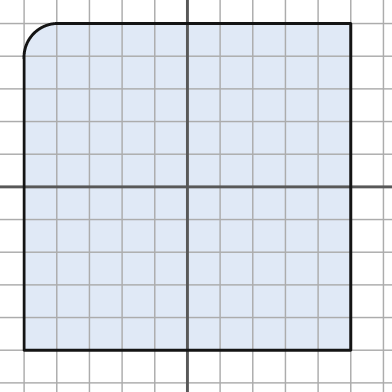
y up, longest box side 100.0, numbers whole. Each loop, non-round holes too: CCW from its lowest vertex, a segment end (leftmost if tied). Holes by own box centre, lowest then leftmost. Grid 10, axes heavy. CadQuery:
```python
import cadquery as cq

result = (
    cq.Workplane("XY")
    .moveTo(-50.0, -50.0)
    .lineTo(50.0, -50.0)
    .lineTo(50.0, 50.0)
    .lineTo(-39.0, 50.0)
    .threePointArc((-47.0, 47.0), (-50.0, 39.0))
    .close()
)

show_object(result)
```